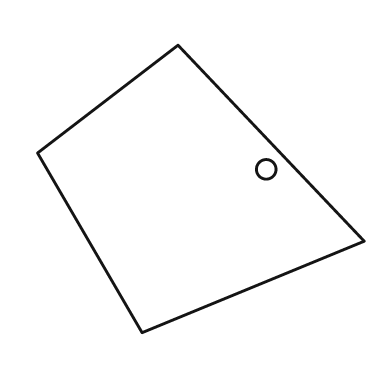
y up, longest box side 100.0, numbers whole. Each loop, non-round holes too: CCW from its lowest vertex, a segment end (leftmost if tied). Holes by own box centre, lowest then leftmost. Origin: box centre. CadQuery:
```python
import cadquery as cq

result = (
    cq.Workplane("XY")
    .moveTo(-18.0, -44.0)
    .lineTo(50.0, -16.0)
    .lineTo(-7.0, 44.0)
    .lineTo(-50.0, 11.0)
    .close()
    .moveTo(20.0, 6.0)
    .circle(3.0)
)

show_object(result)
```